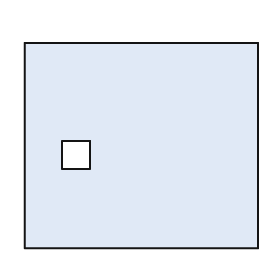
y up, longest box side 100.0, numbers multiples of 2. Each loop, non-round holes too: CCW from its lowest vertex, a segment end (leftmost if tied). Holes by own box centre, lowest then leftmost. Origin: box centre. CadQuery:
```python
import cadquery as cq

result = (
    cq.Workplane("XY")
    .moveTo(-50.0, -44.0)
    .lineTo(50.0, -44.0)
    .lineTo(50.0, 44.0)
    .lineTo(-50.0, 44.0)
    .close()
    .moveTo(-34.0, -10.0)
    .lineTo(-22.0, -10.0)
    .lineTo(-22.0, 2.0)
    .lineTo(-34.0, 2.0)
    .close()
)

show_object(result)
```